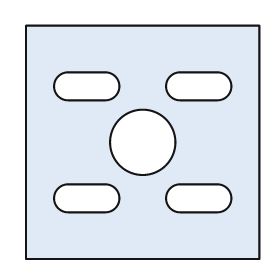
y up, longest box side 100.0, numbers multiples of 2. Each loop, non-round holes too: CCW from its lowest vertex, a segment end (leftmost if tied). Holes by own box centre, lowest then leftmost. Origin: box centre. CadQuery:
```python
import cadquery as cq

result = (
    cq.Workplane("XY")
    .moveTo(-50.0, -50.0)
    .lineTo(50.0, -50.0)
    .lineTo(50.0, 50.0)
    .lineTo(-50.0, 50.0)
    .close()
    .moveTo(-32.0, -30.0)
    .lineTo(-16.0, -30.0)
    .threePointArc((-10.0, -24.0), (-16.0, -18.0))
    .lineTo(-32.0, -18.0)
    .threePointArc((-38.0, -24.0), (-32.0, -30.0))
    .close()
    .moveTo(16.0, -30.0)
    .lineTo(32.0, -30.0)
    .threePointArc((38.0, -24.0), (32.0, -18.0))
    .lineTo(16.0, -18.0)
    .threePointArc((10.0, -24.0), (16.0, -30.0))
    .close()
    .moveTo(0.0, 0.0)
    .circle(14.0)
    .moveTo(-32.0, 18.0)
    .lineTo(-16.0, 18.0)
    .threePointArc((-10.0, 24.0), (-16.0, 30.0))
    .lineTo(-32.0, 30.0)
    .threePointArc((-38.0, 24.0), (-32.0, 18.0))
    .close()
    .moveTo(16.0, 18.0)
    .lineTo(32.0, 18.0)
    .threePointArc((38.0, 24.0), (32.0, 30.0))
    .lineTo(16.0, 30.0)
    .threePointArc((10.0, 24.0), (16.0, 18.0))
    .close()
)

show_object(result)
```